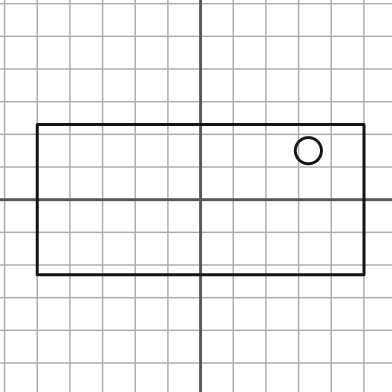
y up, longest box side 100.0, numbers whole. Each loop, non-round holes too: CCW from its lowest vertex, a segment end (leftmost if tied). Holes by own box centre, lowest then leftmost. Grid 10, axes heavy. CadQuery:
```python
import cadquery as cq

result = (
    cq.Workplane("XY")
    .moveTo(-50.0, -23.0)
    .lineTo(50.0, -23.0)
    .lineTo(50.0, 23.0)
    .lineTo(-50.0, 23.0)
    .close()
    .moveTo(33.0, 15.0)
    .circle(4.0)
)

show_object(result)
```